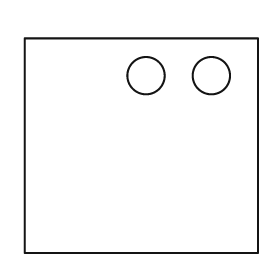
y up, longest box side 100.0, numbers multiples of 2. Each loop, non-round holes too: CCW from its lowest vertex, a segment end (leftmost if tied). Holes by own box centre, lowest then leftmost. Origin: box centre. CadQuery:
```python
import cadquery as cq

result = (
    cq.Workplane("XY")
    .moveTo(-50.0, -46.0)
    .lineTo(50.0, -46.0)
    .lineTo(50.0, 46.0)
    .lineTo(-50.0, 46.0)
    .close()
    .moveTo(2.0, 30.0)
    .circle(8.0)
    .moveTo(30.0, 30.0)
    .circle(8.0)
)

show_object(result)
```